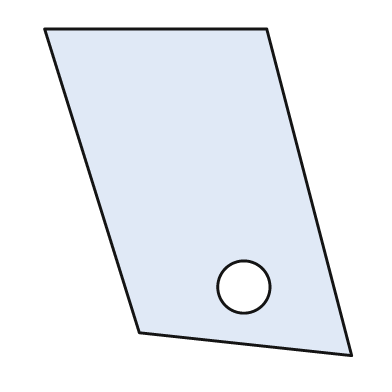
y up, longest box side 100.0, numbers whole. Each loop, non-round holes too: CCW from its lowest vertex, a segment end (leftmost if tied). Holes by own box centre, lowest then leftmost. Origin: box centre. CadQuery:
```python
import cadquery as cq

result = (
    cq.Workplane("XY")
    .moveTo(47.0, -50.0)
    .lineTo(21.0, 50.0)
    .lineTo(-47.0, 50.0)
    .lineTo(-18.0, -43.0)
    .close()
    .moveTo(14.0, -29.0)
    .circle(8.0)
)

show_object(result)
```